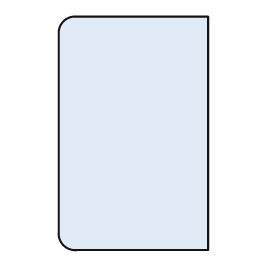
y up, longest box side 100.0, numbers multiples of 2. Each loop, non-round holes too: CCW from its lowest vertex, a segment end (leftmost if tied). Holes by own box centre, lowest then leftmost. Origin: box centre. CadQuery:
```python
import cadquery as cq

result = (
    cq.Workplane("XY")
    .moveTo(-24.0, -50.0)
    .lineTo(32.0, -50.0)
    .lineTo(32.0, 50.0)
    .lineTo(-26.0, 50.0)
    .threePointArc((-30.0, 48.0), (-32.0, 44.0))
    .lineTo(-32.0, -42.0)
    .threePointArc((-30.0, -48.0), (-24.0, -50.0))
    .close()
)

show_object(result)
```